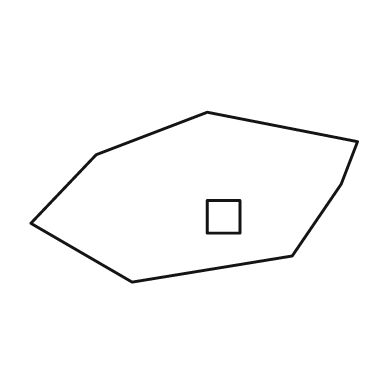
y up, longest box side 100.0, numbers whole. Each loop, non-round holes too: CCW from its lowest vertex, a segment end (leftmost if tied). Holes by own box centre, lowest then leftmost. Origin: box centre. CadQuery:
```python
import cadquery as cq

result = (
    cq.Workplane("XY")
    .moveTo(-19.0, -26.0)
    .lineTo(30.0, -18.0)
    .lineTo(45.0, 4.0)
    .lineTo(50.0, 17.0)
    .lineTo(4.0, 26.0)
    .lineTo(-30.0, 13.0)
    .lineTo(-50.0, -8.0)
    .close()
    .moveTo(4.0, -11.0)
    .lineTo(14.0, -11.0)
    .lineTo(14.0, -1.0)
    .lineTo(4.0, -1.0)
    .close()
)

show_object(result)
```